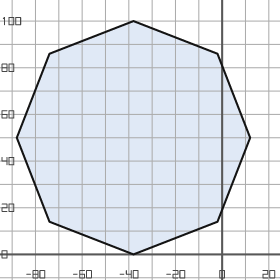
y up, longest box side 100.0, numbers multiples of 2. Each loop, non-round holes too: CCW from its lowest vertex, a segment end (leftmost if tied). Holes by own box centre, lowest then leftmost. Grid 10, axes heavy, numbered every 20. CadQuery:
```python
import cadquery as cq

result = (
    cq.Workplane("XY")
    .moveTo(-38.0, 0.0)
    .lineTo(-2.0, 14.0)
    .lineTo(12.0, 50.0)
    .lineTo(-2.0, 86.0)
    .lineTo(-38.0, 100.0)
    .lineTo(-74.0, 86.0)
    .lineTo(-88.0, 50.0)
    .lineTo(-74.0, 14.0)
    .close()
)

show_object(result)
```